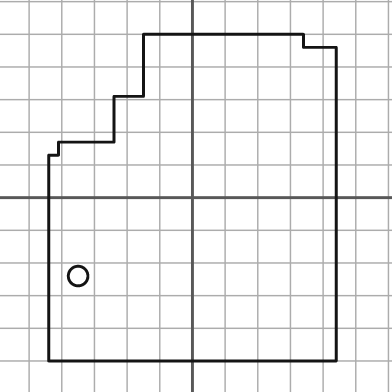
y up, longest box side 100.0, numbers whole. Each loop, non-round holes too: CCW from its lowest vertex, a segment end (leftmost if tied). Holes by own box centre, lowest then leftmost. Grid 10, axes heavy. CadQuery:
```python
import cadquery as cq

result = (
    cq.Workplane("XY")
    .moveTo(-44.0, -50.0)
    .lineTo(44.0, -50.0)
    .lineTo(44.0, 46.0)
    .lineTo(34.0, 46.0)
    .lineTo(34.0, 50.0)
    .lineTo(-15.0, 50.0)
    .lineTo(-15.0, 31.0)
    .lineTo(-24.0, 31.0)
    .lineTo(-24.0, 17.0)
    .lineTo(-41.0, 17.0)
    .lineTo(-41.0, 13.0)
    .lineTo(-44.0, 13.0)
    .close()
    .moveTo(-35.0, -24.0)
    .circle(3.0)
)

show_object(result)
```